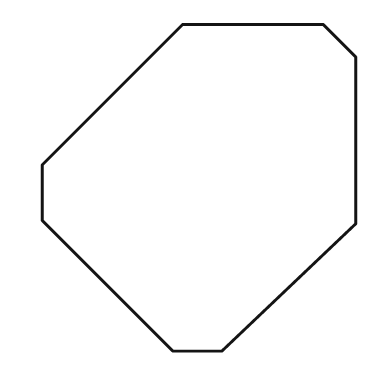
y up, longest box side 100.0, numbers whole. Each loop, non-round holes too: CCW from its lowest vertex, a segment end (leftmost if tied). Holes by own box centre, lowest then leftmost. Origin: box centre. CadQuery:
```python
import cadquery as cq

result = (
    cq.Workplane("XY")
    .moveTo(-8.0, -50.0)
    .lineTo(7.0, -50.0)
    .lineTo(48.0, -11.0)
    .lineTo(48.0, 40.0)
    .lineTo(38.0, 50.0)
    .lineTo(-5.0, 50.0)
    .lineTo(-48.0, 7.0)
    .lineTo(-48.0, -10.0)
    .close()
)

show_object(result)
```